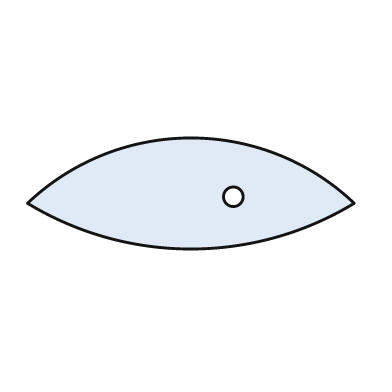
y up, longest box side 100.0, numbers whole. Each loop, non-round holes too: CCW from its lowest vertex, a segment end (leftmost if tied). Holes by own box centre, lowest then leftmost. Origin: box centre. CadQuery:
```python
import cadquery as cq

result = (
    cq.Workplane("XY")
    .moveTo(-50.0, -3.0)
    .threePointArc((0.0, -17.0), (50.0, -3.0))
    .threePointArc((0.0, 17.0), (-50.0, -3.0))
    .close()
    .moveTo(13.0, -1.0)
    .circle(3.0)
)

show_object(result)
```